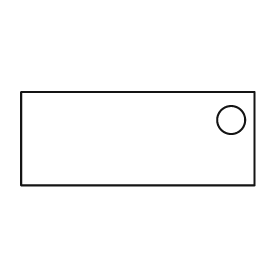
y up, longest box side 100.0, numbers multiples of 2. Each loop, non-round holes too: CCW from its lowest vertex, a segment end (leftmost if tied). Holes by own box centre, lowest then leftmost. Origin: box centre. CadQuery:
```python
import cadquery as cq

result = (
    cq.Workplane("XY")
    .moveTo(-50.0, -20.0)
    .lineTo(50.0, -20.0)
    .lineTo(50.0, 20.0)
    .lineTo(-50.0, 20.0)
    .close()
    .moveTo(40.0, 8.0)
    .circle(6.0)
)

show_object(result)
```